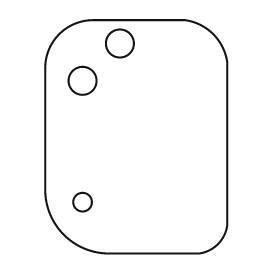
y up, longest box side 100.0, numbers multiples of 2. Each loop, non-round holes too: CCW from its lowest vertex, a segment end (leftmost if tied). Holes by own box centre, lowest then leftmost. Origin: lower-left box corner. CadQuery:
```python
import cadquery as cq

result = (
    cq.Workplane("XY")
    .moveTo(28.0, 0.0)
    .lineTo(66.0, 0.0)
    .threePointArc((74.0, 4.0), (78.0, 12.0))
    .lineTo(78.0, 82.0)
    .threePointArc((72.0, 94.0), (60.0, 100.0))
    .lineTo(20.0, 100.0)
    .threePointArc((6.0, 94.0), (0.0, 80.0))
    .lineTo(0.0, 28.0)
    .threePointArc((8.0, 8.0), (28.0, 0.0))
    .close()
    .moveTo(16.0, 22.0)
    .circle(4.0)
    .moveTo(16.0, 74.0)
    .circle(6.0)
    .moveTo(32.0, 90.0)
    .circle(6.0)
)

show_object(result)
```